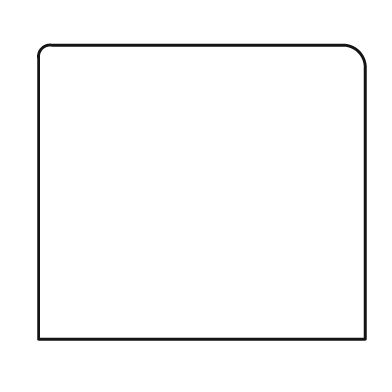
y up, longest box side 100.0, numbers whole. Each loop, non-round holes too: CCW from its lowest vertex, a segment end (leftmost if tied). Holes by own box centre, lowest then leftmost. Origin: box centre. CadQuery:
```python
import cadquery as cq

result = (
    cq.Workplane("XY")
    .moveTo(-50.0, -45.0)
    .lineTo(50.0, -45.0)
    .lineTo(50.0, 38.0)
    .threePointArc((48.0, 43.0), (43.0, 45.0))
    .lineTo(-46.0, 45.0)
    .threePointArc((-49.0, 44.0), (-50.0, 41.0))
    .close()
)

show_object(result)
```